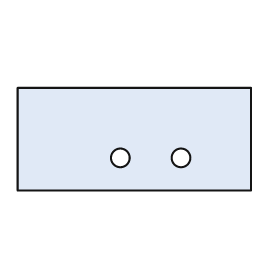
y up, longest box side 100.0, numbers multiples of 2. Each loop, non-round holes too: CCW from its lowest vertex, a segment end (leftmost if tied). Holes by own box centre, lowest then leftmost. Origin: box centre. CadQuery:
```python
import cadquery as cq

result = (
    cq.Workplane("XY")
    .moveTo(-50.0, -22.0)
    .lineTo(50.0, -22.0)
    .lineTo(50.0, 22.0)
    .lineTo(-50.0, 22.0)
    .close()
    .moveTo(-6.0, -8.0)
    .circle(4.0)
    .moveTo(20.0, -8.0)
    .circle(4.0)
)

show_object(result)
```